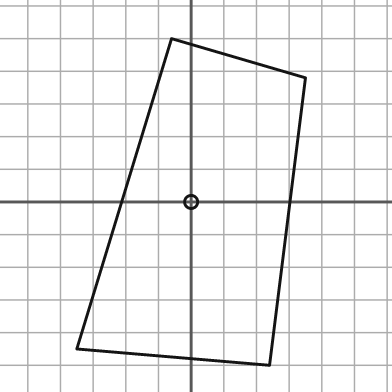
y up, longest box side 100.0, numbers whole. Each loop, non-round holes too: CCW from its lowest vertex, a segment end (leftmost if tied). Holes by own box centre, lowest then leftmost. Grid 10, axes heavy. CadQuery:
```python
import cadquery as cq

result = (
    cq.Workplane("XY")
    .moveTo(24.0, -50.0)
    .lineTo(35.0, 38.0)
    .lineTo(-6.0, 50.0)
    .lineTo(-35.0, -45.0)
    .close()
    .moveTo(0.0, 0.0)
    .circle(2.0)
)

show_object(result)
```